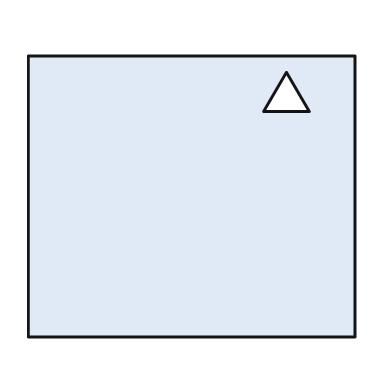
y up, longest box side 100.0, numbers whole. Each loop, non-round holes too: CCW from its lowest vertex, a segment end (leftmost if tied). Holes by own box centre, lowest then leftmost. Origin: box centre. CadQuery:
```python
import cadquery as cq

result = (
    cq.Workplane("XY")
    .moveTo(-50.0, -43.0)
    .lineTo(50.0, -43.0)
    .lineTo(50.0, 43.0)
    .lineTo(-50.0, 43.0)
    .close()
    .moveTo(22.0, 26.0)
    .lineTo(36.0, 26.0)
    .lineTo(29.0, 38.0)
    .close()
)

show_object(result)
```